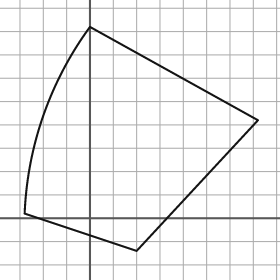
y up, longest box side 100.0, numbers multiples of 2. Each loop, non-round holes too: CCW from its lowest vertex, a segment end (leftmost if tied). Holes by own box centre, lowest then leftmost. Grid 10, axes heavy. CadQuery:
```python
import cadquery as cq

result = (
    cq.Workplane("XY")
    .moveTo(20.0, -14.0)
    .lineTo(72.0, 42.0)
    .lineTo(0.0, 82.0)
    .threePointArc((-20.0, 44.0), (-28.0, 2.0))
    .close()
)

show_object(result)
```